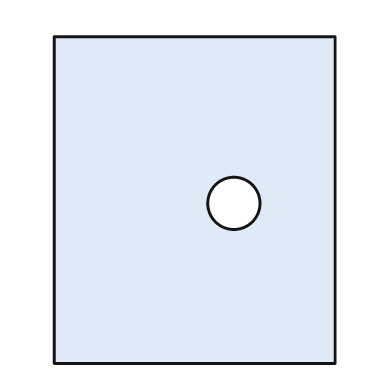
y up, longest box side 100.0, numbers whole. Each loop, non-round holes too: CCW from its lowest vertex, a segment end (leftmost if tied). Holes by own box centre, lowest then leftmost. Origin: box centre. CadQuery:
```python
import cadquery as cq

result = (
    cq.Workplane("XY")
    .moveTo(-43.0, -50.0)
    .lineTo(43.0, -50.0)
    .lineTo(43.0, 50.0)
    .lineTo(-43.0, 50.0)
    .close()
    .moveTo(12.0, -1.0)
    .circle(8.0)
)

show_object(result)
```